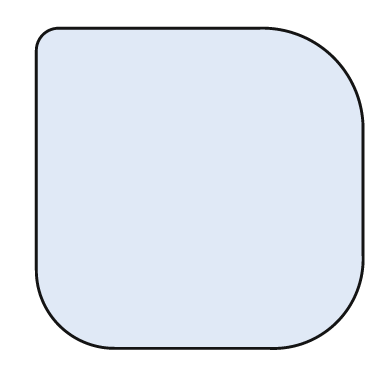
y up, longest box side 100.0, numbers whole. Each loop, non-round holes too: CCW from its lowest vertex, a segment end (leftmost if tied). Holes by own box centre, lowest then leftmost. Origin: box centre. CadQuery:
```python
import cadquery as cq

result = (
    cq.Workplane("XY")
    .moveTo(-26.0, -49.0)
    .lineTo(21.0, -49.0)
    .threePointArc((42.0, -41.0), (50.0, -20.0))
    .lineTo(50.0, 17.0)
    .threePointArc((41.0, 40.0), (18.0, 49.0))
    .lineTo(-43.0, 49.0)
    .threePointArc((-48.0, 47.0), (-50.0, 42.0))
    .lineTo(-50.0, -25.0)
    .threePointArc((-43.0, -42.0), (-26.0, -49.0))
    .close()
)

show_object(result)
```